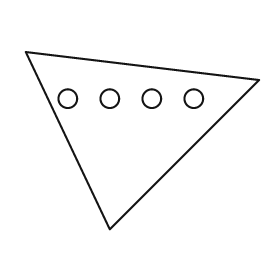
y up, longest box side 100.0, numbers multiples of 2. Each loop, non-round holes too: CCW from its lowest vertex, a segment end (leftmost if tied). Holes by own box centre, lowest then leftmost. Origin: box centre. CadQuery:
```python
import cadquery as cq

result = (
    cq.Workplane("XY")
    .moveTo(-14.0, -38.0)
    .lineTo(50.0, 26.0)
    .lineTo(-50.0, 38.0)
    .close()
    .moveTo(-32.0, 18.0)
    .circle(4.0)
    .moveTo(-14.0, 18.0)
    .circle(4.0)
    .moveTo(4.0, 18.0)
    .circle(4.0)
    .moveTo(22.0, 18.0)
    .circle(4.0)
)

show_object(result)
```